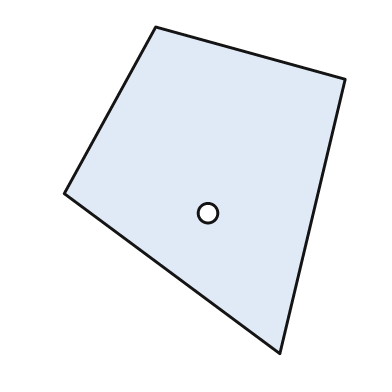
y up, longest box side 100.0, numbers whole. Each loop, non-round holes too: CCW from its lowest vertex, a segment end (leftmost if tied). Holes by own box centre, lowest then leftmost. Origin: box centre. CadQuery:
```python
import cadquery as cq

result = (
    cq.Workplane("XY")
    .moveTo(23.0, -50.0)
    .lineTo(43.0, 34.0)
    .lineTo(-15.0, 50.0)
    .lineTo(-43.0, -1.0)
    .close()
    .moveTo(1.0, -7.0)
    .circle(3.0)
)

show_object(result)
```